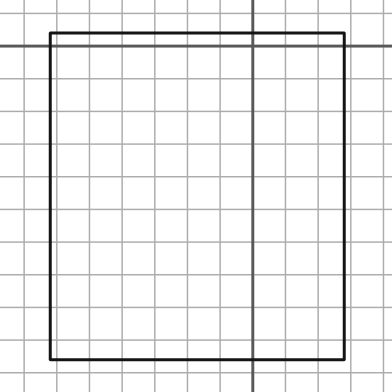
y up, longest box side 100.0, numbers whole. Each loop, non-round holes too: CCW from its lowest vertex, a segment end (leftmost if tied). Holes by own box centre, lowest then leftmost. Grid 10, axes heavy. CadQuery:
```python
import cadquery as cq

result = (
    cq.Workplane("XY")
    .moveTo(-62.0, -96.0)
    .lineTo(28.0, -96.0)
    .lineTo(28.0, 4.0)
    .lineTo(-62.0, 4.0)
    .close()
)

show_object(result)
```